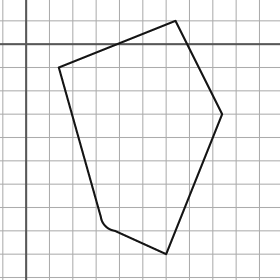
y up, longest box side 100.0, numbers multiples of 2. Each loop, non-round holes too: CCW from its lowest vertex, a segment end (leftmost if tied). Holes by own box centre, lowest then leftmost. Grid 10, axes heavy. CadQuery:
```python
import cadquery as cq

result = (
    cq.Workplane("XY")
    .moveTo(60.0, -90.0)
    .lineTo(84.0, -30.0)
    .lineTo(64.0, 10.0)
    .lineTo(14.0, -10.0)
    .lineTo(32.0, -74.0)
    .threePointArc((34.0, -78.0), (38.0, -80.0))
    .close()
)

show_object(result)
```